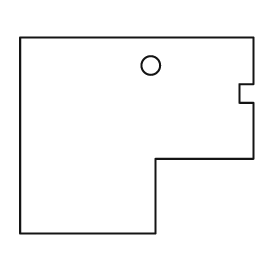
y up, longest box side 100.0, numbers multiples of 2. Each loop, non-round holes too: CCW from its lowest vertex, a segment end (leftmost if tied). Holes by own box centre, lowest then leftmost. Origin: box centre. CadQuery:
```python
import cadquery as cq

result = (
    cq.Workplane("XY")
    .moveTo(-50.0, -42.0)
    .lineTo(8.0, -42.0)
    .lineTo(8.0, -10.0)
    .lineTo(50.0, -10.0)
    .lineTo(50.0, 14.0)
    .lineTo(44.0, 14.0)
    .lineTo(44.0, 22.0)
    .lineTo(50.0, 22.0)
    .lineTo(50.0, 42.0)
    .lineTo(-50.0, 42.0)
    .close()
    .moveTo(6.0, 30.0)
    .circle(4.0)
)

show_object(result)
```